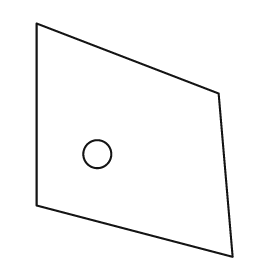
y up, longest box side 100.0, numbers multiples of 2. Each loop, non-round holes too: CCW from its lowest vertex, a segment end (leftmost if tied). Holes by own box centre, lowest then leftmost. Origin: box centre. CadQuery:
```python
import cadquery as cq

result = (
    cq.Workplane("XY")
    .moveTo(42.0, -50.0)
    .lineTo(36.0, 20.0)
    .lineTo(-42.0, 50.0)
    .lineTo(-42.0, -28.0)
    .close()
    .moveTo(-16.0, -6.0)
    .circle(6.0)
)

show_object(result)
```